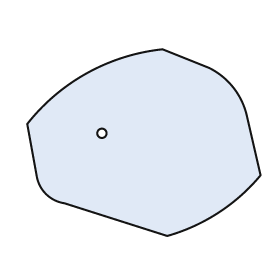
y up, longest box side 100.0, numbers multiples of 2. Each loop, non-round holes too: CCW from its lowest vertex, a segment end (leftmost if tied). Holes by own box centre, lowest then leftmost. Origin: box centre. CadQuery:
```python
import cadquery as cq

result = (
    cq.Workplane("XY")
    .moveTo(10.0, -40.0)
    .threePointArc((32.0, -30.0), (50.0, -14.0))
    .lineTo(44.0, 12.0)
    .threePointArc((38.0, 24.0), (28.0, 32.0))
    .lineTo(8.0, 40.0)
    .threePointArc((-24.0, 30.0), (-50.0, 8.0))
    .lineTo(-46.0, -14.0)
    .threePointArc((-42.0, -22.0), (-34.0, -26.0))
    .close()
    .moveTo(-18.0, 4.0)
    .circle(2.0)
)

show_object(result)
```